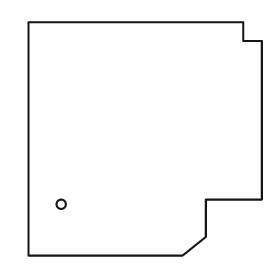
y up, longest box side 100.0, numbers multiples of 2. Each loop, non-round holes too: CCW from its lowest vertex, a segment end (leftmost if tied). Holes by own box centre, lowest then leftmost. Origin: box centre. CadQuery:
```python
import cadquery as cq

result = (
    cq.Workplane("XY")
    .moveTo(-50.0, -50.0)
    .lineTo(16.0, -50.0)
    .lineTo(26.0, -42.0)
    .lineTo(26.0, -26.0)
    .lineTo(50.0, -26.0)
    .lineTo(50.0, 42.0)
    .lineTo(42.0, 42.0)
    .lineTo(42.0, 50.0)
    .lineTo(-50.0, 50.0)
    .close()
    .moveTo(-36.0, -28.0)
    .circle(2.0)
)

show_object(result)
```